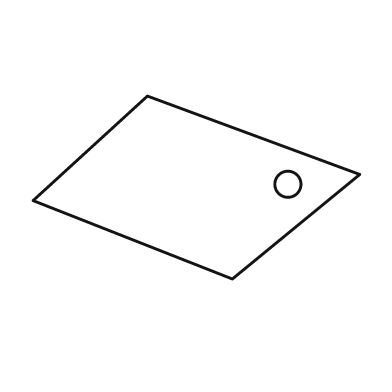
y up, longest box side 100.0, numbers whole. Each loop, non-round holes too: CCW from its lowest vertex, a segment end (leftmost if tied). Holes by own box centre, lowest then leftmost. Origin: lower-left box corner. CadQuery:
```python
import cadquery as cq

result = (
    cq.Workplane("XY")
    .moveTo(61.0, 0.0)
    .lineTo(100.0, 32.0)
    .lineTo(35.0, 56.0)
    .lineTo(0.0, 24.0)
    .close()
    .moveTo(78.0, 29.0)
    .circle(4.0)
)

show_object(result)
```